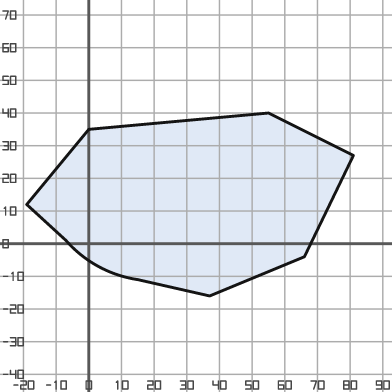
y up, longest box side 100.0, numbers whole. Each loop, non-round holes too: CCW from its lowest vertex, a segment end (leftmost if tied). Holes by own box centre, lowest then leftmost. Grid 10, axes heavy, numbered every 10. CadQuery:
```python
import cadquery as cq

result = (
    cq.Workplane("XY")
    .moveTo(37.0, -16.0)
    .lineTo(66.0, -4.0)
    .lineTo(81.0, 27.0)
    .lineTo(55.0, 40.0)
    .lineTo(0.0, 35.0)
    .lineTo(-19.0, 12.0)
    .lineTo(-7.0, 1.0)
    .threePointArc((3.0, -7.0), (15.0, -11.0))
    .close()
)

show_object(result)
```